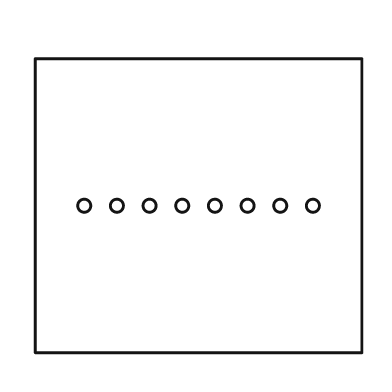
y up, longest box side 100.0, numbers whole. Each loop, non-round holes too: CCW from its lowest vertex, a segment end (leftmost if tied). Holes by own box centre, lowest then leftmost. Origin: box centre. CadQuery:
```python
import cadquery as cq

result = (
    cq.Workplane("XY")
    .moveTo(-50.0, -45.0)
    .lineTo(50.0, -45.0)
    .lineTo(50.0, 45.0)
    .lineTo(-50.0, 45.0)
    .close()
    .moveTo(-35.0, 0.0)
    .circle(2.0)
    .moveTo(-25.0, 0.0)
    .circle(2.0)
    .moveTo(-15.0, 0.0)
    .circle(2.0)
    .moveTo(-5.0, 0.0)
    .circle(2.0)
    .moveTo(5.0, 0.0)
    .circle(2.0)
    .moveTo(15.0, 0.0)
    .circle(2.0)
    .moveTo(25.0, 0.0)
    .circle(2.0)
    .moveTo(35.0, 0.0)
    .circle(2.0)
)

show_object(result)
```